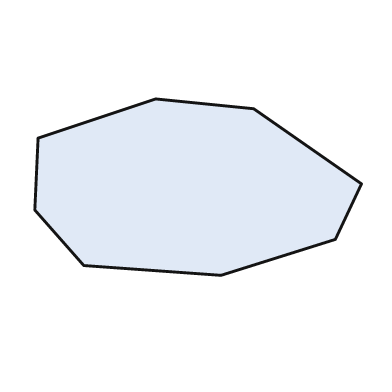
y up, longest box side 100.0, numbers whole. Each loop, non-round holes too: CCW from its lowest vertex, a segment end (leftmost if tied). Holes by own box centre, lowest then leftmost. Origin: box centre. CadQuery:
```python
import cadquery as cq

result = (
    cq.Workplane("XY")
    .moveTo(7.0, -27.0)
    .lineTo(42.0, -16.0)
    .lineTo(50.0, 1.0)
    .lineTo(17.0, 24.0)
    .lineTo(-13.0, 27.0)
    .lineTo(-49.0, 15.0)
    .lineTo(-50.0, -7.0)
    .lineTo(-35.0, -24.0)
    .close()
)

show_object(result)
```